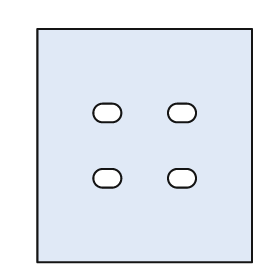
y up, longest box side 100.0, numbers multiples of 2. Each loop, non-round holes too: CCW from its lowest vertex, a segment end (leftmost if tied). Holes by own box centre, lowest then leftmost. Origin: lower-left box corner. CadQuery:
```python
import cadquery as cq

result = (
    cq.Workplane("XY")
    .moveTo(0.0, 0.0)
    .lineTo(92.0, 0.0)
    .lineTo(92.0, 100.0)
    .lineTo(0.0, 100.0)
    .close()
    .moveTo(28.0, 32.0)
    .lineTo(32.0, 32.0)
    .threePointArc((36.0, 36.0), (32.0, 40.0))
    .lineTo(28.0, 40.0)
    .threePointArc((24.0, 36.0), (28.0, 32.0))
    .close()
    .moveTo(60.0, 32.0)
    .lineTo(64.0, 32.0)
    .threePointArc((68.0, 36.0), (64.0, 40.0))
    .lineTo(60.0, 40.0)
    .threePointArc((56.0, 36.0), (60.0, 32.0))
    .close()
    .moveTo(28.0, 60.0)
    .lineTo(32.0, 60.0)
    .threePointArc((36.0, 64.0), (32.0, 68.0))
    .lineTo(28.0, 68.0)
    .threePointArc((24.0, 64.0), (28.0, 60.0))
    .close()
    .moveTo(60.0, 60.0)
    .lineTo(64.0, 60.0)
    .threePointArc((68.0, 64.0), (64.0, 68.0))
    .lineTo(60.0, 68.0)
    .threePointArc((56.0, 64.0), (60.0, 60.0))
    .close()
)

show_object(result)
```